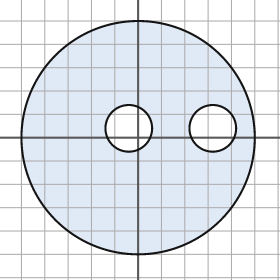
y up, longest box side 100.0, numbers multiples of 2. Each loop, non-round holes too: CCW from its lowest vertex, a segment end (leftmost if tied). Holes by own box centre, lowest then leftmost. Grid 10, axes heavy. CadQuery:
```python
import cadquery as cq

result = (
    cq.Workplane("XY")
    .moveTo(0.0, 0.0)
    .circle(50.0)
    .moveTo(-4.0, 4.0)
    .circle(10.0)
    .moveTo(32.0, 4.0)
    .circle(10.0)
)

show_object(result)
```